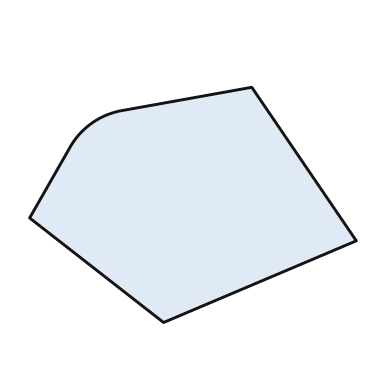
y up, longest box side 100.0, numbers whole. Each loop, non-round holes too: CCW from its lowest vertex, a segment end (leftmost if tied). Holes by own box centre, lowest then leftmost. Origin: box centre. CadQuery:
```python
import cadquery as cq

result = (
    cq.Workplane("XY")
    .moveTo(-9.0, -36.0)
    .lineTo(50.0, -11.0)
    .lineTo(18.0, 36.0)
    .lineTo(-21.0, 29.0)
    .threePointArc((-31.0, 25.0), (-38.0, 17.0))
    .lineTo(-50.0, -4.0)
    .close()
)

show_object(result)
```